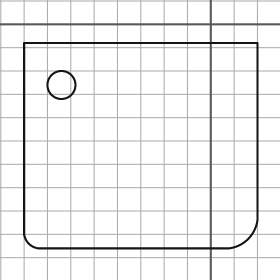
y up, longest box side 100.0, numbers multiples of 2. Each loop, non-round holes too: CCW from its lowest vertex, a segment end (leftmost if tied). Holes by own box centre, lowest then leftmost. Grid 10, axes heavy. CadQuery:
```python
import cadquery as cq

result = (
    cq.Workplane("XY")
    .moveTo(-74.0, -96.0)
    .lineTo(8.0, -96.0)
    .threePointArc((16.0, -92.0), (20.0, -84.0))
    .lineTo(20.0, -8.0)
    .lineTo(-80.0, -8.0)
    .lineTo(-80.0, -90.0)
    .threePointArc((-78.0, -94.0), (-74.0, -96.0))
    .close()
    .moveTo(-64.0, -26.0)
    .circle(6.0)
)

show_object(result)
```